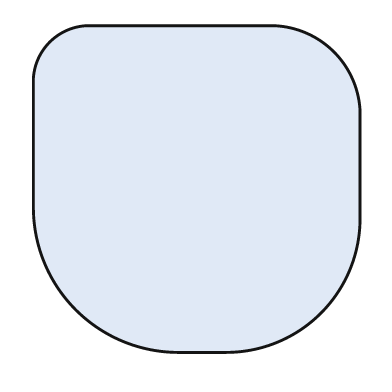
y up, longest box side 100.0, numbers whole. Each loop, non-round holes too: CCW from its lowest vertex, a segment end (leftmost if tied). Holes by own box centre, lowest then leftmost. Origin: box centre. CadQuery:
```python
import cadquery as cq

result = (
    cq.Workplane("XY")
    .moveTo(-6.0, -50.0)
    .lineTo(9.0, -50.0)
    .threePointArc((38.0, -38.0), (50.0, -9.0))
    .lineTo(50.0, 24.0)
    .threePointArc((42.0, 42.0), (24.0, 50.0))
    .lineTo(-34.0, 50.0)
    .threePointArc((-45.0, 45.0), (-50.0, 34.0))
    .lineTo(-50.0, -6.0)
    .threePointArc((-37.0, -37.0), (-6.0, -50.0))
    .close()
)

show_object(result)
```